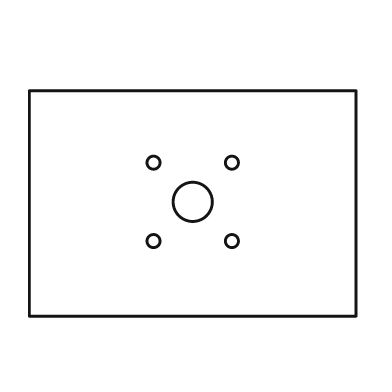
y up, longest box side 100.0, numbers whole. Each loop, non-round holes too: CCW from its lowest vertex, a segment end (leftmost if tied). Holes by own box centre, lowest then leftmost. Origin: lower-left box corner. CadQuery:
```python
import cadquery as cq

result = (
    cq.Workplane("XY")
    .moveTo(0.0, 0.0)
    .lineTo(100.0, 0.0)
    .lineTo(100.0, 69.0)
    .lineTo(0.0, 69.0)
    .close()
    .moveTo(38.0, 23.0)
    .circle(2.0)
    .moveTo(62.0, 23.0)
    .circle(2.0)
    .moveTo(50.0, 35.0)
    .circle(6.0)
    .moveTo(38.0, 47.0)
    .circle(2.0)
    .moveTo(62.0, 47.0)
    .circle(2.0)
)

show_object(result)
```